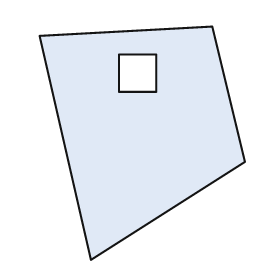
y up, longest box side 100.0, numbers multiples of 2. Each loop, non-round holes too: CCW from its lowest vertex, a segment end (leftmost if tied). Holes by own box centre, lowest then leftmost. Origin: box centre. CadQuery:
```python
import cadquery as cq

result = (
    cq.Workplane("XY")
    .moveTo(-22.0, -50.0)
    .lineTo(44.0, -8.0)
    .lineTo(30.0, 50.0)
    .lineTo(-44.0, 46.0)
    .close()
    .moveTo(-10.0, 22.0)
    .lineTo(6.0, 22.0)
    .lineTo(6.0, 38.0)
    .lineTo(-10.0, 38.0)
    .close()
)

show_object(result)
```